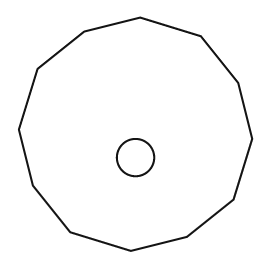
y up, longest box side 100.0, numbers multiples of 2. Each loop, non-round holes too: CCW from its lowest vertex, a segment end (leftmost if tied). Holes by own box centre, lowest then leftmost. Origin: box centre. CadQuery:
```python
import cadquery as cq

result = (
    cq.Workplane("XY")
    .moveTo(-2.0, -50.0)
    .lineTo(22.0, -44.0)
    .lineTo(42.0, -28.0)
    .lineTo(50.0, -2.0)
    .lineTo(44.0, 22.0)
    .lineTo(28.0, 42.0)
    .lineTo(2.0, 50.0)
    .lineTo(-22.0, 44.0)
    .lineTo(-42.0, 28.0)
    .lineTo(-50.0, 2.0)
    .lineTo(-44.0, -22.0)
    .lineTo(-28.0, -42.0)
    .close()
    .moveTo(0.0, -10.0)
    .circle(8.0)
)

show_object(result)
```